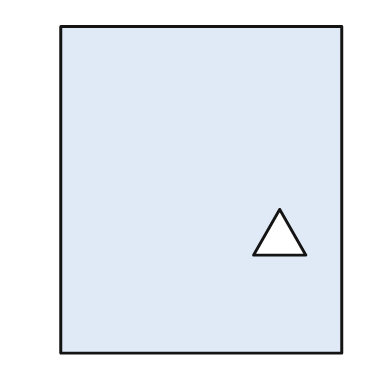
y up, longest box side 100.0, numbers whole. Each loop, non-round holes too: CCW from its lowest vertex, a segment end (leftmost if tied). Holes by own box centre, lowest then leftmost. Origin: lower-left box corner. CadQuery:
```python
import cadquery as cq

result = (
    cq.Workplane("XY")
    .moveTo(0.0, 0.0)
    .lineTo(86.0, 0.0)
    .lineTo(86.0, 100.0)
    .lineTo(0.0, 100.0)
    .close()
    .moveTo(59.0, 30.0)
    .lineTo(75.0, 30.0)
    .lineTo(67.0, 44.0)
    .close()
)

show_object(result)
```